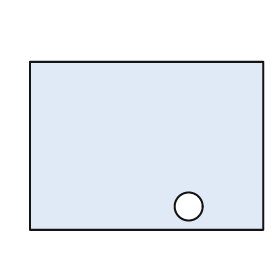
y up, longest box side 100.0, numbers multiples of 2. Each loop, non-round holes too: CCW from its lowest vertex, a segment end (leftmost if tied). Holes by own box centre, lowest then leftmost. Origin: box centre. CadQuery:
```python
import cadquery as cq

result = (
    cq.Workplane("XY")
    .moveTo(-50.0, -36.0)
    .lineTo(50.0, -36.0)
    .lineTo(50.0, 36.0)
    .lineTo(-50.0, 36.0)
    .close()
    .moveTo(18.0, -26.0)
    .circle(6.0)
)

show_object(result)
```